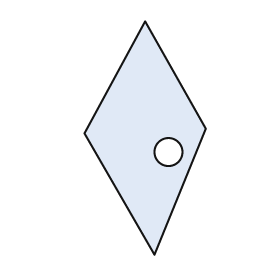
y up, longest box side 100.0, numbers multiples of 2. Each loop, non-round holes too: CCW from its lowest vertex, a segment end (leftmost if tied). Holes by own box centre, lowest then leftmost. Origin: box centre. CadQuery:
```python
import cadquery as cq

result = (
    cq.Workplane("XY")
    .moveTo(4.0, -50.0)
    .lineTo(26.0, 4.0)
    .lineTo(0.0, 50.0)
    .lineTo(-26.0, 2.0)
    .close()
    .moveTo(10.0, -6.0)
    .circle(6.0)
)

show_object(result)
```